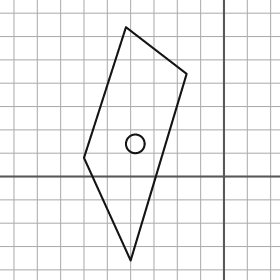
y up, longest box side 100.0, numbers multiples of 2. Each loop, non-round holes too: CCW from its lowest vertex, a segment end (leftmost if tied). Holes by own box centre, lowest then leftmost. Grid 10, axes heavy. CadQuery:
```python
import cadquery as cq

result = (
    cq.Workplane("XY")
    .moveTo(-40.0, -36.0)
    .lineTo(-16.0, 44.0)
    .lineTo(-42.0, 64.0)
    .lineTo(-60.0, 8.0)
    .close()
    .moveTo(-38.0, 14.0)
    .circle(4.0)
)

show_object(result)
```